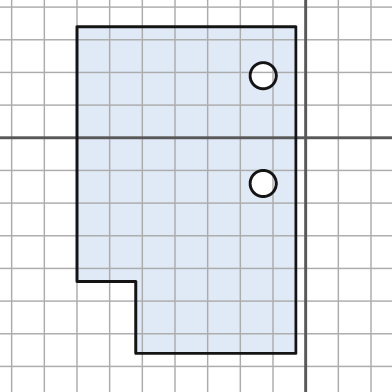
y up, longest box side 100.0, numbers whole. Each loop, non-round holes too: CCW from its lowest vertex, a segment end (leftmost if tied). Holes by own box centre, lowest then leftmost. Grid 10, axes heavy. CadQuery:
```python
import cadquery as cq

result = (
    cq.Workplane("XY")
    .moveTo(-52.0, -66.0)
    .lineTo(-3.0, -66.0)
    .lineTo(-3.0, 34.0)
    .lineTo(-70.0, 34.0)
    .lineTo(-70.0, -44.0)
    .lineTo(-52.0, -44.0)
    .close()
    .moveTo(-13.0, -14.0)
    .circle(4.0)
    .moveTo(-13.0, 19.0)
    .circle(4.0)
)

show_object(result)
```